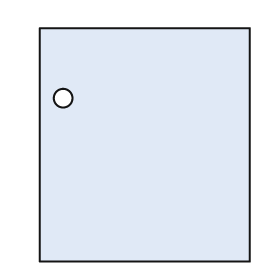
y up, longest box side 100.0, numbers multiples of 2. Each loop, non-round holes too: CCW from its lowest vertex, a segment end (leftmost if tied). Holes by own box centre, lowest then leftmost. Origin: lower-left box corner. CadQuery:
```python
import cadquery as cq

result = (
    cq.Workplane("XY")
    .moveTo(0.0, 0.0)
    .lineTo(90.0, 0.0)
    .lineTo(90.0, 100.0)
    .lineTo(0.0, 100.0)
    .close()
    .moveTo(10.0, 70.0)
    .circle(4.0)
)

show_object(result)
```